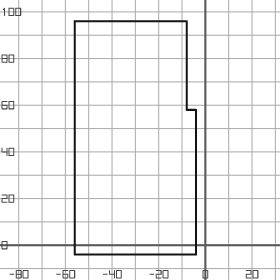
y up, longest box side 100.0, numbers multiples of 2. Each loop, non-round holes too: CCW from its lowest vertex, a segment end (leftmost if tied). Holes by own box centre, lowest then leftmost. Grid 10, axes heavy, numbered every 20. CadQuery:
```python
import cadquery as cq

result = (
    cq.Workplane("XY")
    .moveTo(-56.0, -4.0)
    .lineTo(-4.0, -4.0)
    .lineTo(-4.0, 58.0)
    .lineTo(-8.0, 58.0)
    .lineTo(-8.0, 96.0)
    .lineTo(-56.0, 96.0)
    .close()
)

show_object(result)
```